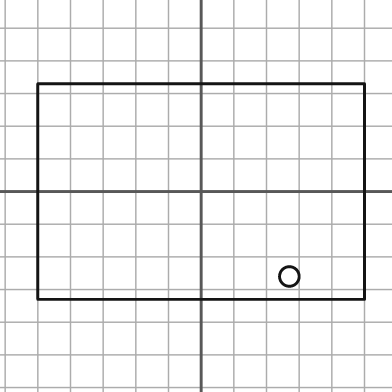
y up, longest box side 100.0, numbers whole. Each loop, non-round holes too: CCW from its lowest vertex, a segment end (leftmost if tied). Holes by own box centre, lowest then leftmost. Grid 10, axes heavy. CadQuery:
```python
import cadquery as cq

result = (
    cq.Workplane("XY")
    .moveTo(-50.0, -33.0)
    .lineTo(50.0, -33.0)
    .lineTo(50.0, 33.0)
    .lineTo(-50.0, 33.0)
    .close()
    .moveTo(27.0, -26.0)
    .circle(3.0)
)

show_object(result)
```